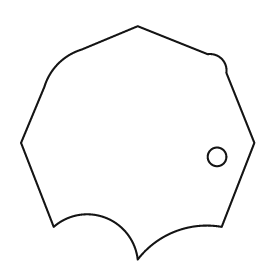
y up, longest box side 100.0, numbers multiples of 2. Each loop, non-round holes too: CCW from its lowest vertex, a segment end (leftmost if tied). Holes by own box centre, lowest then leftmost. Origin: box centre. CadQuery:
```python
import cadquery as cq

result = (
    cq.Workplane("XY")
    .moveTo(0.0, -50.0)
    .threePointArc((16.0, -38.0), (36.0, -36.0))
    .lineTo(50.0, 0.0)
    .lineTo(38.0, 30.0)
    .threePointArc((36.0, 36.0), (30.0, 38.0))
    .lineTo(0.0, 50.0)
    .lineTo(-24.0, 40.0)
    .threePointArc((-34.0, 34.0), (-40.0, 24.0))
    .lineTo(-50.0, 0.0)
    .lineTo(-36.0, -36.0)
    .threePointArc((-14.0, -32.0), (0.0, -50.0))
    .close()
    .moveTo(34.0, -6.0)
    .circle(4.0)
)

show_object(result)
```